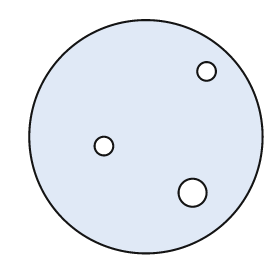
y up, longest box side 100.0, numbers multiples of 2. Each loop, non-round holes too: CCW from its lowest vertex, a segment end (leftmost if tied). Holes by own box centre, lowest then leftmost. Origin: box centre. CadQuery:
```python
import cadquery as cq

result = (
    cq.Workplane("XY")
    .moveTo(0.0, 0.0)
    .circle(50.0)
    .moveTo(20.0, -24.0)
    .circle(6.0)
    .moveTo(-18.0, -4.0)
    .circle(4.0)
    .moveTo(26.0, 28.0)
    .circle(4.0)
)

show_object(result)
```